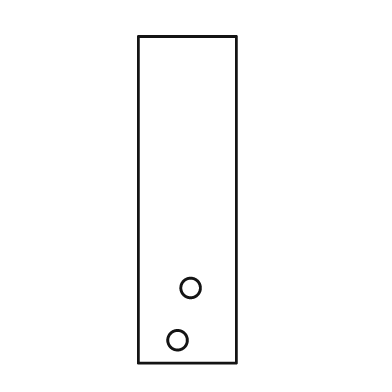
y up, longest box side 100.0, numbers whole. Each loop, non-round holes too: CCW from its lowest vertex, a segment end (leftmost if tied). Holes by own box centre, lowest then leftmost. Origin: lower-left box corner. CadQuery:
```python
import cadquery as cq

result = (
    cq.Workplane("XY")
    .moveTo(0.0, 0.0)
    .lineTo(30.0, 0.0)
    .lineTo(30.0, 100.0)
    .lineTo(0.0, 100.0)
    .close()
    .moveTo(12.0, 7.0)
    .circle(3.0)
    .moveTo(16.0, 23.0)
    .circle(3.0)
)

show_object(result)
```